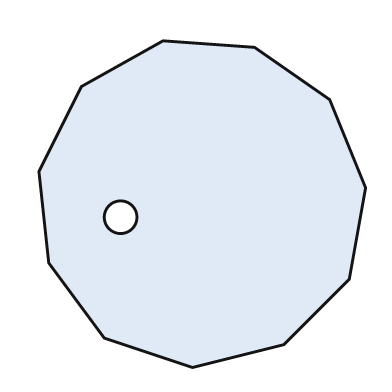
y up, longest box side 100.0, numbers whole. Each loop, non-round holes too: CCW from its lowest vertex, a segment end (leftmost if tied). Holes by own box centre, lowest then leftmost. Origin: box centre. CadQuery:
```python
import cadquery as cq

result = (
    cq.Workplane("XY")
    .moveTo(-3.0, -50.0)
    .lineTo(25.0, -43.0)
    .lineTo(45.0, -23.0)
    .lineTo(50.0, 5.0)
    .lineTo(39.0, 32.0)
    .lineTo(16.0, 48.0)
    .lineTo(-12.0, 50.0)
    .lineTo(-37.0, 36.0)
    .lineTo(-50.0, 10.0)
    .lineTo(-47.0, -18.0)
    .lineTo(-30.0, -41.0)
    .close()
    .moveTo(-25.0, -4.0)
    .circle(5.0)
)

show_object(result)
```